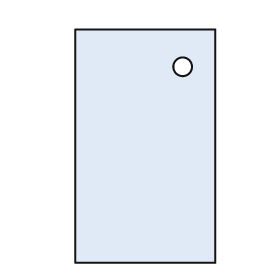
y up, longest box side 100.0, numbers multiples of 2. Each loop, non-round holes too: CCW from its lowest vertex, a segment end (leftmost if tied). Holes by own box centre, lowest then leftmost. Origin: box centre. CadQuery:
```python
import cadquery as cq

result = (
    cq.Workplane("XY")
    .moveTo(-30.0, -50.0)
    .lineTo(30.0, -50.0)
    .lineTo(30.0, 50.0)
    .lineTo(-30.0, 50.0)
    .close()
    .moveTo(16.0, 34.0)
    .circle(4.0)
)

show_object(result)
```